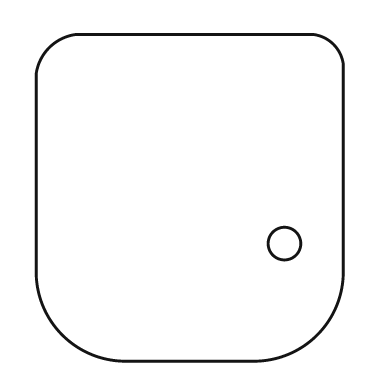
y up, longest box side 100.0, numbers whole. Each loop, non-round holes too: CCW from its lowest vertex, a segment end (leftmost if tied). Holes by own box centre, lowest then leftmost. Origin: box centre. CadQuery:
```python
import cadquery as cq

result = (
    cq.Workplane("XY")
    .moveTo(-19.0, -50.0)
    .lineTo(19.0, -50.0)
    .threePointArc((39.0, -42.0), (47.0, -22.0))
    .lineTo(47.0, 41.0)
    .threePointArc((44.0, 47.0), (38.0, 50.0))
    .lineTo(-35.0, 50.0)
    .threePointArc((-43.0, 46.0), (-47.0, 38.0))
    .lineTo(-47.0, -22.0)
    .threePointArc((-39.0, -42.0), (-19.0, -50.0))
    .close()
    .moveTo(29.0, -14.0)
    .circle(5.0)
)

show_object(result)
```